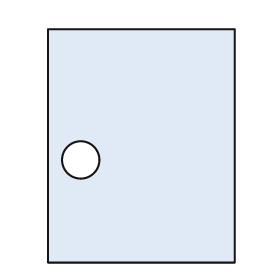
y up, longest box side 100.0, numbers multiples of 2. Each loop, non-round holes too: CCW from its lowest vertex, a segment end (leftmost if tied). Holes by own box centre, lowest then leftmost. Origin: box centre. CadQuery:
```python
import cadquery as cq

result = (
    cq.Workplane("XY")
    .moveTo(-40.0, -50.0)
    .lineTo(40.0, -50.0)
    .lineTo(40.0, 50.0)
    .lineTo(-40.0, 50.0)
    .close()
    .moveTo(-26.0, -6.0)
    .circle(8.0)
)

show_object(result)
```